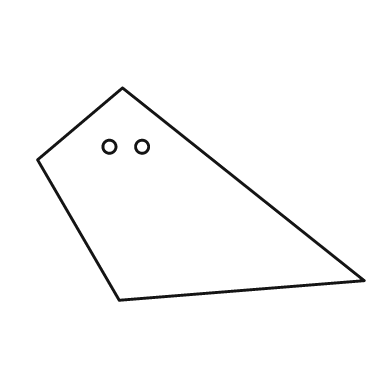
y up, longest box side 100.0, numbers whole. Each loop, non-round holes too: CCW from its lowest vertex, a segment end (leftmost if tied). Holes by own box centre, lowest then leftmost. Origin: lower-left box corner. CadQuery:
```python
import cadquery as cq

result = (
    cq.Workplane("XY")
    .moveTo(25.0, 0.0)
    .lineTo(100.0, 6.0)
    .lineTo(26.0, 65.0)
    .lineTo(0.0, 43.0)
    .close()
    .moveTo(22.0, 47.0)
    .circle(2.0)
    .moveTo(32.0, 47.0)
    .circle(2.0)
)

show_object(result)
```